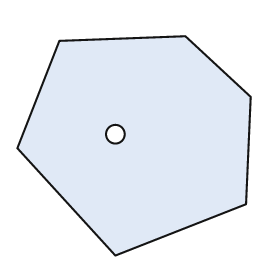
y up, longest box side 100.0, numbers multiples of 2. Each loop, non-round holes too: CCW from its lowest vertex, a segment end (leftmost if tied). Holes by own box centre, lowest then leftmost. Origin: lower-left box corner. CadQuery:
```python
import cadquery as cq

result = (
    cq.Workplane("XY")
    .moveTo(42.0, 0.0)
    .lineTo(98.0, 22.0)
    .lineTo(100.0, 68.0)
    .lineTo(72.0, 94.0)
    .lineTo(18.0, 92.0)
    .lineTo(0.0, 46.0)
    .close()
    .moveTo(42.0, 52.0)
    .circle(4.0)
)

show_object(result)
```